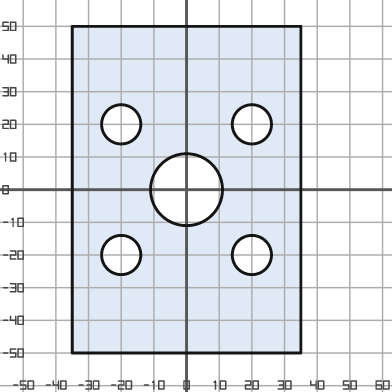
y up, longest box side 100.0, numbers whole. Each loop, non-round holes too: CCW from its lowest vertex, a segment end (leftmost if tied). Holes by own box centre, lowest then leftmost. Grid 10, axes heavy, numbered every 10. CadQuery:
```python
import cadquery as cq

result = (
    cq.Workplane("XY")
    .moveTo(-35.0, -50.0)
    .lineTo(35.0, -50.0)
    .lineTo(35.0, 50.0)
    .lineTo(-35.0, 50.0)
    .close()
    .moveTo(-20.0, -20.0)
    .circle(6.0)
    .moveTo(20.0, -20.0)
    .circle(6.0)
    .moveTo(0.0, 0.0)
    .circle(11.0)
    .moveTo(-20.0, 20.0)
    .circle(6.0)
    .moveTo(20.0, 20.0)
    .circle(6.0)
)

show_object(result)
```